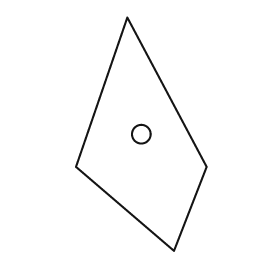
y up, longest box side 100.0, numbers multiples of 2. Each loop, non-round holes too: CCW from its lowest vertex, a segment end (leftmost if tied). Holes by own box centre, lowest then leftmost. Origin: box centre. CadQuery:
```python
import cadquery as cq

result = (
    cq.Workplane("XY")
    .moveTo(14.0, -50.0)
    .lineTo(28.0, -14.0)
    .lineTo(-6.0, 50.0)
    .lineTo(-28.0, -14.0)
    .close()
    .moveTo(0.0, 0.0)
    .circle(4.0)
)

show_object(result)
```